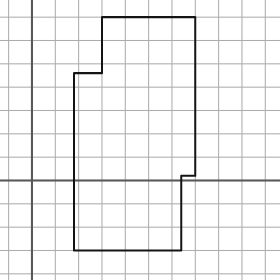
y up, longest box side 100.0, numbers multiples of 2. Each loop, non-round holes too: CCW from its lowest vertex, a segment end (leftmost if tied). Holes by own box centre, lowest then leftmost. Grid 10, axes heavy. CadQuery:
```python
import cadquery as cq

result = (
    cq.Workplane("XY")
    .moveTo(18.0, -30.0)
    .lineTo(64.0, -30.0)
    .lineTo(64.0, 2.0)
    .lineTo(70.0, 2.0)
    .lineTo(70.0, 70.0)
    .lineTo(30.0, 70.0)
    .lineTo(30.0, 46.0)
    .lineTo(18.0, 46.0)
    .close()
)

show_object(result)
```